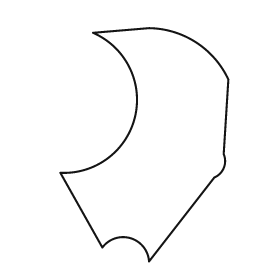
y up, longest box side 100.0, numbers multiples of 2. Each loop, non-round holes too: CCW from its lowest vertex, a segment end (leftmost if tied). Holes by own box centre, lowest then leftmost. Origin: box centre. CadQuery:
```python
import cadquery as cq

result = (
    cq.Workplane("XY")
    .moveTo(2.0, -50.0)
    .lineTo(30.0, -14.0)
    .threePointArc((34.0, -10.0), (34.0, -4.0))
    .lineTo(36.0, 28.0)
    .threePointArc((22.0, 44.0), (2.0, 50.0))
    .lineTo(-22.0, 48.0)
    .threePointArc((-4.0, 12.0), (-36.0, -12.0))
    .lineTo(-18.0, -44.0)
    .threePointArc((-6.0, -40.0), (2.0, -50.0))
    .close()
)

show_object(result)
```